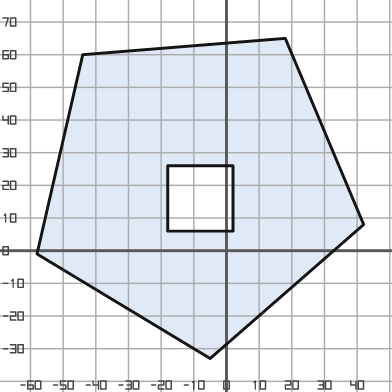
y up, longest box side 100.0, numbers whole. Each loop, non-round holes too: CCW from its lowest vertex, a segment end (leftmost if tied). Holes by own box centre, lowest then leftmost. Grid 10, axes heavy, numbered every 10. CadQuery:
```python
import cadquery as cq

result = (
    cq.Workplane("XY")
    .moveTo(-5.0, -33.0)
    .lineTo(42.0, 8.0)
    .lineTo(18.0, 65.0)
    .lineTo(-44.0, 60.0)
    .lineTo(-58.0, -1.0)
    .close()
    .moveTo(-18.0, 6.0)
    .lineTo(2.0, 6.0)
    .lineTo(2.0, 26.0)
    .lineTo(-18.0, 26.0)
    .close()
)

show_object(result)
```